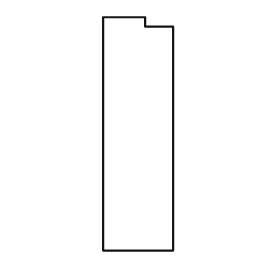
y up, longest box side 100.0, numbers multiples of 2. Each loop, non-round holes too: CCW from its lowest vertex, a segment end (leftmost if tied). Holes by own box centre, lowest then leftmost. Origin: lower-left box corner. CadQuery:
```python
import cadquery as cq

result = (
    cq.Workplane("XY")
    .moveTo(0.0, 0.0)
    .lineTo(30.0, 0.0)
    .lineTo(30.0, 96.0)
    .lineTo(18.0, 96.0)
    .lineTo(18.0, 100.0)
    .lineTo(0.0, 100.0)
    .close()
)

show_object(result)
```